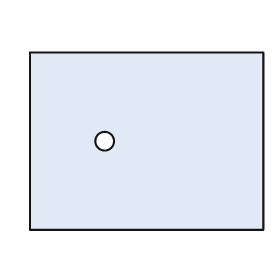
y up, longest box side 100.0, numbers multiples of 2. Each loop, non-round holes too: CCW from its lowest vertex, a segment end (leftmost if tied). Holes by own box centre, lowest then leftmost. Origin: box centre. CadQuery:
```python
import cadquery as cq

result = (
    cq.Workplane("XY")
    .moveTo(-50.0, -38.0)
    .lineTo(50.0, -38.0)
    .lineTo(50.0, 38.0)
    .lineTo(-50.0, 38.0)
    .close()
    .moveTo(-18.0, 0.0)
    .circle(4.0)
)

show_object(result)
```